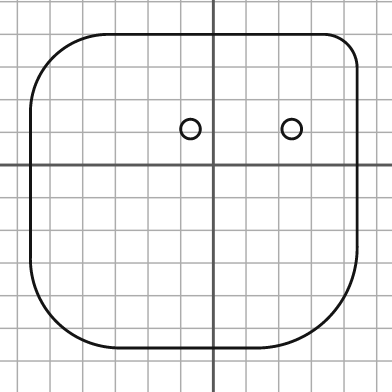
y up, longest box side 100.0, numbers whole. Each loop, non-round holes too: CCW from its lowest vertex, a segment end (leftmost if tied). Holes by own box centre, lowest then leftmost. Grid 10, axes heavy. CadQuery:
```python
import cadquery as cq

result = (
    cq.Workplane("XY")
    .moveTo(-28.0, -56.0)
    .lineTo(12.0, -56.0)
    .threePointArc((35.0, -47.0), (44.0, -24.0))
    .lineTo(44.0, 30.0)
    .threePointArc((41.0, 37.0), (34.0, 40.0))
    .lineTo(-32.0, 40.0)
    .threePointArc((-49.0, 33.0), (-56.0, 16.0))
    .lineTo(-56.0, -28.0)
    .threePointArc((-48.0, -48.0), (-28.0, -56.0))
    .close()
    .moveTo(-7.0, 11.0)
    .circle(3.0)
    .moveTo(24.0, 11.0)
    .circle(3.0)
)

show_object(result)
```